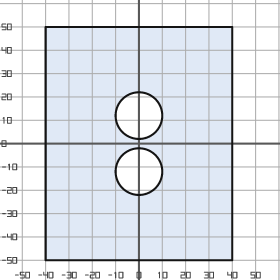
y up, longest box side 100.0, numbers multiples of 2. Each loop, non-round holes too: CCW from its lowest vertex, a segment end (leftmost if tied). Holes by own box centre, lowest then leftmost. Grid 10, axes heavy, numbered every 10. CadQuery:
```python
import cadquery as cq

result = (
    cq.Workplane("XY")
    .moveTo(-40.0, -50.0)
    .lineTo(40.0, -50.0)
    .lineTo(40.0, 50.0)
    .lineTo(-40.0, 50.0)
    .close()
    .moveTo(0.0, -12.0)
    .circle(10.0)
    .moveTo(0.0, 12.0)
    .circle(10.0)
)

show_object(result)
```